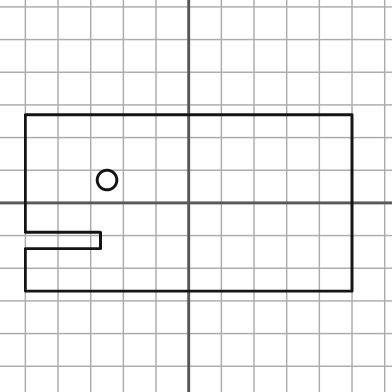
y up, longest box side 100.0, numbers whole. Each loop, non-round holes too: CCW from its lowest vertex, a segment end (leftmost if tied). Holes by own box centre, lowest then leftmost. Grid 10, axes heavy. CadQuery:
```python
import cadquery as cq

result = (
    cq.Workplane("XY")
    .moveTo(-50.0, -27.0)
    .lineTo(50.0, -27.0)
    .lineTo(50.0, 27.0)
    .lineTo(-50.0, 27.0)
    .lineTo(-50.0, -9.0)
    .lineTo(-27.0, -9.0)
    .lineTo(-27.0, -14.0)
    .lineTo(-50.0, -14.0)
    .close()
    .moveTo(-25.0, 7.0)
    .circle(3.0)
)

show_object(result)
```